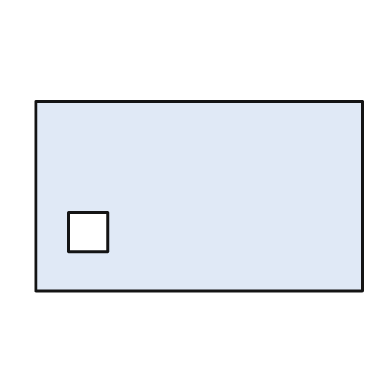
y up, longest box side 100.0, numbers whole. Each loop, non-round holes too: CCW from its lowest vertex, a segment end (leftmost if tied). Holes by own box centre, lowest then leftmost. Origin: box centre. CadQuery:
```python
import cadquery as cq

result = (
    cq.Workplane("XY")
    .moveTo(-50.0, -29.0)
    .lineTo(50.0, -29.0)
    .lineTo(50.0, 29.0)
    .lineTo(-50.0, 29.0)
    .close()
    .moveTo(-40.0, -17.0)
    .lineTo(-28.0, -17.0)
    .lineTo(-28.0, -5.0)
    .lineTo(-40.0, -5.0)
    .close()
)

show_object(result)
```